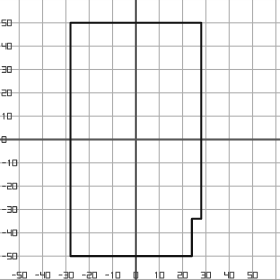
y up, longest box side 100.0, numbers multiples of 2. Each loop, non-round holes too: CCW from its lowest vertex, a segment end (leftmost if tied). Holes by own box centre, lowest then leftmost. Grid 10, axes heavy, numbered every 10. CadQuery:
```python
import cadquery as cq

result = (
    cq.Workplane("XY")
    .moveTo(-28.0, -50.0)
    .lineTo(24.0, -50.0)
    .lineTo(24.0, -34.0)
    .lineTo(28.0, -34.0)
    .lineTo(28.0, 50.0)
    .lineTo(-28.0, 50.0)
    .close()
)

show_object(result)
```